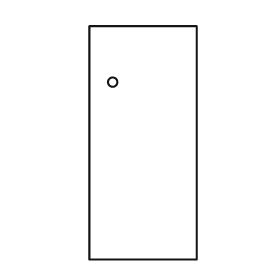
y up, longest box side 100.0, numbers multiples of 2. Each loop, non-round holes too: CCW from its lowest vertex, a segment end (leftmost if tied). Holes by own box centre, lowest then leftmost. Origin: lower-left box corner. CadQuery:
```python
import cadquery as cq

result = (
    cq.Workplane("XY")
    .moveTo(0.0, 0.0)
    .lineTo(46.0, 0.0)
    .lineTo(46.0, 100.0)
    .lineTo(0.0, 100.0)
    .close()
    .moveTo(10.0, 76.0)
    .circle(2.0)
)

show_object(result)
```